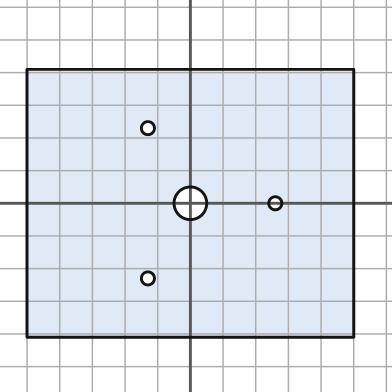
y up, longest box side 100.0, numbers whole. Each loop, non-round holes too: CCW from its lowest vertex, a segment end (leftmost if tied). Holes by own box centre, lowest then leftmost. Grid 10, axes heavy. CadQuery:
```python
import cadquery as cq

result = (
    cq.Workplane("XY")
    .moveTo(-50.0, -41.0)
    .lineTo(50.0, -41.0)
    .lineTo(50.0, 41.0)
    .lineTo(-50.0, 41.0)
    .close()
    .moveTo(-13.0, -23.0)
    .circle(2.0)
    .moveTo(0.0, 0.0)
    .circle(5.0)
    .moveTo(26.0, 0.0)
    .circle(2.0)
    .moveTo(-13.0, 23.0)
    .circle(2.0)
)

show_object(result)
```